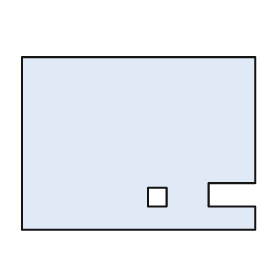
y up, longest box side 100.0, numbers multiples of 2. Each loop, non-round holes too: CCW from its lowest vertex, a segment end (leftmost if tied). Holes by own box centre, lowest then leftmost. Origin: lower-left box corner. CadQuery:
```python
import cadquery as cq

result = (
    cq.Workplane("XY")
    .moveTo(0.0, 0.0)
    .lineTo(100.0, 0.0)
    .lineTo(100.0, 10.0)
    .lineTo(80.0, 10.0)
    .lineTo(80.0, 20.0)
    .lineTo(100.0, 20.0)
    .lineTo(100.0, 74.0)
    .lineTo(0.0, 74.0)
    .close()
    .moveTo(54.0, 10.0)
    .lineTo(62.0, 10.0)
    .lineTo(62.0, 18.0)
    .lineTo(54.0, 18.0)
    .close()
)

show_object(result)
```